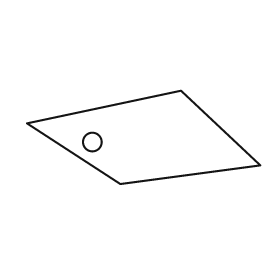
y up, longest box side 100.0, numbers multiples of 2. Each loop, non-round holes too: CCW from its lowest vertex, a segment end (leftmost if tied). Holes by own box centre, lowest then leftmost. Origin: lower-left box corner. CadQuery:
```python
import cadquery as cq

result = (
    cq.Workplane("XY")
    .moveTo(40.0, 0.0)
    .lineTo(100.0, 8.0)
    .lineTo(66.0, 40.0)
    .lineTo(0.0, 26.0)
    .close()
    .moveTo(28.0, 18.0)
    .circle(4.0)
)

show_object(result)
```